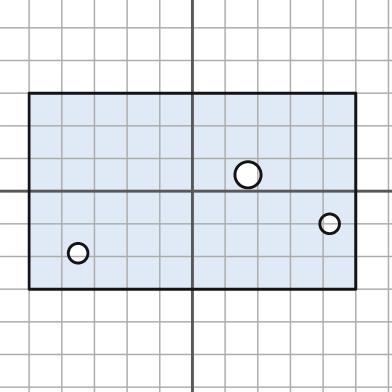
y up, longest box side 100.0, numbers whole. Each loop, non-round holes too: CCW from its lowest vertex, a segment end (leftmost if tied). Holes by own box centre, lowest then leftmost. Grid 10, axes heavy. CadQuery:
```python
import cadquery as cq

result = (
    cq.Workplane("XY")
    .moveTo(-50.0, -30.0)
    .lineTo(50.0, -30.0)
    .lineTo(50.0, 30.0)
    .lineTo(-50.0, 30.0)
    .close()
    .moveTo(-35.0, -19.0)
    .circle(3.0)
    .moveTo(42.0, -10.0)
    .circle(3.0)
    .moveTo(17.0, 5.0)
    .circle(4.0)
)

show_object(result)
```